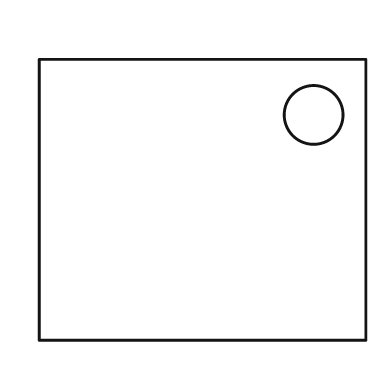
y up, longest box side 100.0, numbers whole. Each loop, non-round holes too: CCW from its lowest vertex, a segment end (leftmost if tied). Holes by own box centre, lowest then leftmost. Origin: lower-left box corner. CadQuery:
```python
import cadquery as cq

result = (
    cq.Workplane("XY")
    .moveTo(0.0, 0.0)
    .lineTo(100.0, 0.0)
    .lineTo(100.0, 86.0)
    .lineTo(0.0, 86.0)
    .close()
    .moveTo(84.0, 69.0)
    .circle(9.0)
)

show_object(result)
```